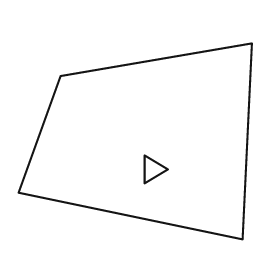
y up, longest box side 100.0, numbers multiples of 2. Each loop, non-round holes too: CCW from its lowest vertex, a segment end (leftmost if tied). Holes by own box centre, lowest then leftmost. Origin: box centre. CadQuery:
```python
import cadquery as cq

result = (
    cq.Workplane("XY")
    .moveTo(46.0, -42.0)
    .lineTo(50.0, 42.0)
    .lineTo(-32.0, 28.0)
    .lineTo(-50.0, -22.0)
    .close()
    .moveTo(4.0, -18.0)
    .lineTo(14.0, -12.0)
    .lineTo(4.0, -6.0)
    .close()
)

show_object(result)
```